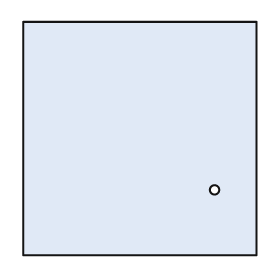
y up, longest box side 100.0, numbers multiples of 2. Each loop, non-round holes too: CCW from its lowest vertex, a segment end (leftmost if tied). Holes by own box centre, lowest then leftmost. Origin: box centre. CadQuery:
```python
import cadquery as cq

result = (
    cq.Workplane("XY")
    .moveTo(-50.0, -50.0)
    .lineTo(50.0, -50.0)
    .lineTo(50.0, 50.0)
    .lineTo(-50.0, 50.0)
    .close()
    .moveTo(32.0, -22.0)
    .circle(2.0)
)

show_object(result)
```